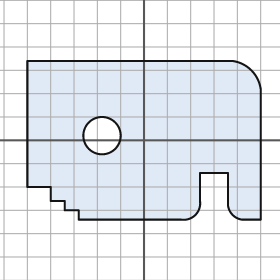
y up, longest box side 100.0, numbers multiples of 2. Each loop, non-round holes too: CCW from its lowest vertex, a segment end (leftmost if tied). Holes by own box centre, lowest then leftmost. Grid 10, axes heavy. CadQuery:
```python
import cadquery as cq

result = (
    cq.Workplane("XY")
    .moveTo(-28.0, -34.0)
    .lineTo(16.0, -34.0)
    .threePointArc((22.0, -32.0), (24.0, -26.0))
    .lineTo(24.0, -14.0)
    .lineTo(36.0, -14.0)
    .lineTo(36.0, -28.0)
    .threePointArc((38.0, -32.0), (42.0, -34.0))
    .lineTo(50.0, -34.0)
    .lineTo(50.0, 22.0)
    .threePointArc((46.0, 30.0), (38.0, 34.0))
    .lineTo(-50.0, 34.0)
    .lineTo(-50.0, -20.0)
    .lineTo(-40.0, -20.0)
    .lineTo(-40.0, -26.0)
    .lineTo(-34.0, -26.0)
    .lineTo(-34.0, -30.0)
    .lineTo(-28.0, -30.0)
    .close()
    .moveTo(-18.0, 2.0)
    .circle(8.0)
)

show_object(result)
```